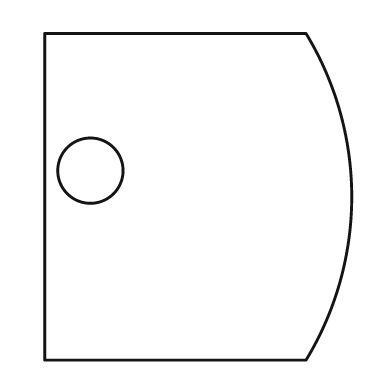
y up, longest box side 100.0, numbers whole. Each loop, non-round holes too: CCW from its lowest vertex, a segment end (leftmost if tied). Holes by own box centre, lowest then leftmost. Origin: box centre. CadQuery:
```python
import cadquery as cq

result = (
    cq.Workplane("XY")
    .moveTo(-47.0, -50.0)
    .lineTo(33.0, -50.0)
    .threePointArc((47.0, 0.0), (33.0, 50.0))
    .lineTo(-47.0, 50.0)
    .close()
    .moveTo(-33.0, 8.0)
    .circle(10.0)
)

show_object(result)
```